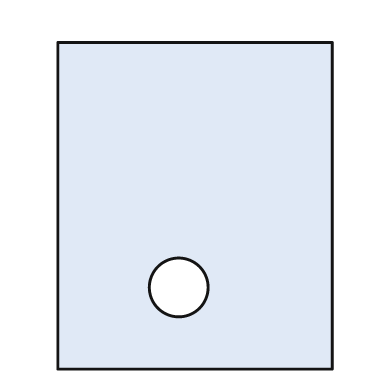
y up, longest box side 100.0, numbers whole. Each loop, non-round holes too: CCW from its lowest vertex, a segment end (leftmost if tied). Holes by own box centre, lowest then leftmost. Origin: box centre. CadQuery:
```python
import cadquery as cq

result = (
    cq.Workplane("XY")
    .moveTo(-42.0, -50.0)
    .lineTo(42.0, -50.0)
    .lineTo(42.0, 50.0)
    .lineTo(-42.0, 50.0)
    .close()
    .moveTo(-5.0, -25.0)
    .circle(9.0)
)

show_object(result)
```